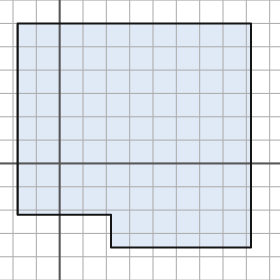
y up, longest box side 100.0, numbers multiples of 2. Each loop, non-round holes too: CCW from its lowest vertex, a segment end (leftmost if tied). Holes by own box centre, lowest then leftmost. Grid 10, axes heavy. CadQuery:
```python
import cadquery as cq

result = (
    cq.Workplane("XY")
    .moveTo(22.0, -36.0)
    .lineTo(82.0, -36.0)
    .lineTo(82.0, 60.0)
    .lineTo(-18.0, 60.0)
    .lineTo(-18.0, -22.0)
    .lineTo(22.0, -22.0)
    .close()
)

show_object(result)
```